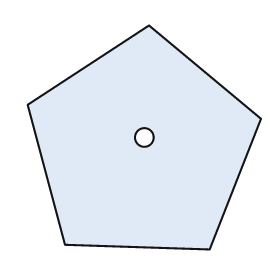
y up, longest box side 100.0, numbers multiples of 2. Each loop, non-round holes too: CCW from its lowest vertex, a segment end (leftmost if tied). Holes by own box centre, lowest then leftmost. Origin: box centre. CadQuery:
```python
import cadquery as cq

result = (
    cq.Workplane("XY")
    .moveTo(28.0, -48.0)
    .lineTo(50.0, 8.0)
    .lineTo(2.0, 48.0)
    .lineTo(-50.0, 14.0)
    .lineTo(-34.0, -46.0)
    .close()
    .moveTo(0.0, 0.0)
    .circle(4.0)
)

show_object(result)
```